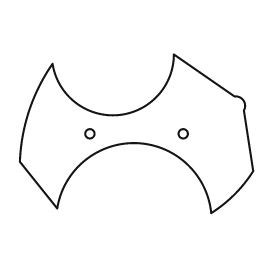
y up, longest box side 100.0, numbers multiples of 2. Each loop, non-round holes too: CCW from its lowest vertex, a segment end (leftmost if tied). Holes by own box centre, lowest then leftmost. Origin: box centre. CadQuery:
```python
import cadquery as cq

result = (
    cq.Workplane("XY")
    .moveTo(32.0, -34.0)
    .threePointArc((42.0, -26.0), (50.0, -16.0))
    .lineTo(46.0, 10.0)
    .threePointArc((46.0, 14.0), (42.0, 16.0))
    .lineTo(16.0, 34.0)
    .threePointArc((-8.0, 8.0), (-36.0, 30.0))
    .threePointArc((-46.0, 10.0), (-50.0, -12.0))
    .lineTo(-34.0, -32.0)
    .threePointArc((0.0, -4.0), (32.0, -34.0))
    .close()
    .moveTo(-20.0, 0.0)
    .circle(2.0)
    .moveTo(20.0, 0.0)
    .circle(2.0)
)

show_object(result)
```